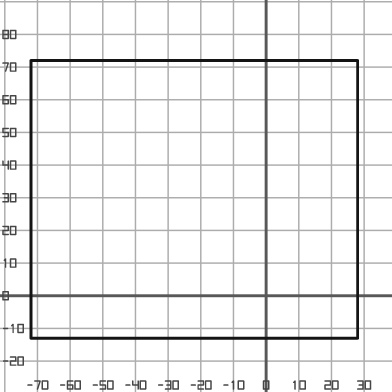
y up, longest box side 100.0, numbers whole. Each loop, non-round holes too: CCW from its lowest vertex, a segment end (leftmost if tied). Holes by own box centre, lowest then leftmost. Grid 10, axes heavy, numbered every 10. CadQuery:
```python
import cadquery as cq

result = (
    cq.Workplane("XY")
    .moveTo(-72.0, -13.0)
    .lineTo(28.0, -13.0)
    .lineTo(28.0, 72.0)
    .lineTo(-72.0, 72.0)
    .close()
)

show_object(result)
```